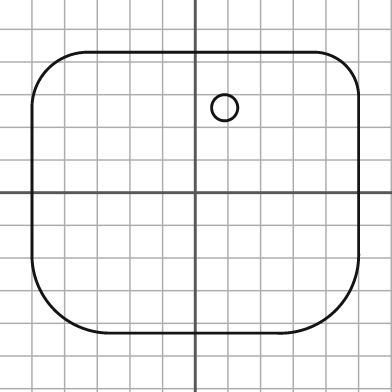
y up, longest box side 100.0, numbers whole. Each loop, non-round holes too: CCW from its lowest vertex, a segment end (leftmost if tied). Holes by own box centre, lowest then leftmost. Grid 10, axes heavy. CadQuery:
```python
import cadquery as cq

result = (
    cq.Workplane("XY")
    .moveTo(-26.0, -43.0)
    .lineTo(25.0, -43.0)
    .threePointArc((43.0, -36.0), (50.0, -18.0))
    .lineTo(50.0, 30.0)
    .threePointArc((46.0, 39.0), (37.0, 43.0))
    .lineTo(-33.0, 43.0)
    .threePointArc((-45.0, 38.0), (-50.0, 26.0))
    .lineTo(-50.0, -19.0)
    .threePointArc((-43.0, -36.0), (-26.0, -43.0))
    .close()
    .moveTo(9.0, 26.0)
    .circle(4.0)
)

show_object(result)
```